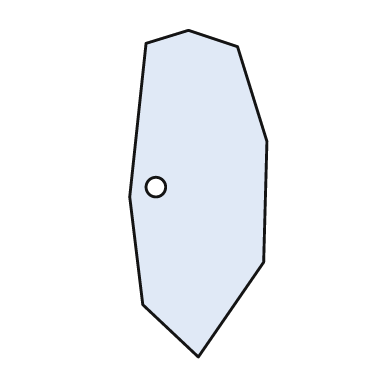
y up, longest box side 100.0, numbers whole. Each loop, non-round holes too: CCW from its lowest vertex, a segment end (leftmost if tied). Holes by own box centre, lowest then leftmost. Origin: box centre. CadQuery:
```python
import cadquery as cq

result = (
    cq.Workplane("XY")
    .moveTo(0.0, -50.0)
    .lineTo(20.0, -21.0)
    .lineTo(21.0, 16.0)
    .lineTo(12.0, 45.0)
    .lineTo(-3.0, 50.0)
    .lineTo(-16.0, 46.0)
    .lineTo(-21.0, -1.0)
    .lineTo(-17.0, -34.0)
    .close()
    .moveTo(-13.0, 2.0)
    .circle(3.0)
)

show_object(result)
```